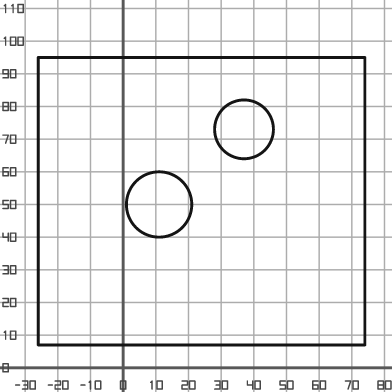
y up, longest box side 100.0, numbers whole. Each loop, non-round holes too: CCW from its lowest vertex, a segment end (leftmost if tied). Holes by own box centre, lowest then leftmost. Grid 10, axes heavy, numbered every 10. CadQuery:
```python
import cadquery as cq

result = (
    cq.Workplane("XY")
    .moveTo(-26.0, 7.0)
    .lineTo(74.0, 7.0)
    .lineTo(74.0, 95.0)
    .lineTo(-26.0, 95.0)
    .close()
    .moveTo(11.0, 50.0)
    .circle(10.0)
    .moveTo(37.0, 73.0)
    .circle(9.0)
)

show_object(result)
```